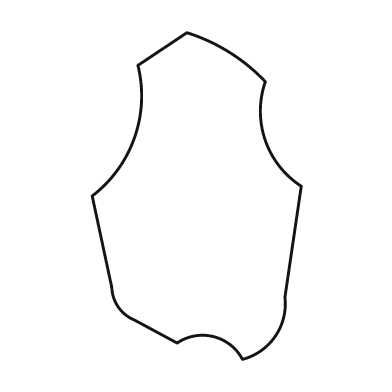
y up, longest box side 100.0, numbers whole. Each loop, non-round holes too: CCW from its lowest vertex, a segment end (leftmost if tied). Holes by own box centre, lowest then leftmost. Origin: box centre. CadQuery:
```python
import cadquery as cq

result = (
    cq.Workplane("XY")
    .moveTo(14.0, -50.0)
    .threePointArc((24.0, -43.0), (27.0, -31.0))
    .lineTo(32.0, 3.0)
    .threePointArc((21.0, 17.0), (21.0, 35.0))
    .threePointArc((10.0, 44.0), (-3.0, 50.0))
    .lineTo(-18.0, 40.0)
    .threePointArc((-19.0, 18.0), (-32.0, 0.0))
    .lineTo(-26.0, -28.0)
    .threePointArc((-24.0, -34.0), (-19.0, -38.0))
    .lineTo(-6.0, -45.0)
    .threePointArc((5.0, -43.0), (14.0, -50.0))
    .close()
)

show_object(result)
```